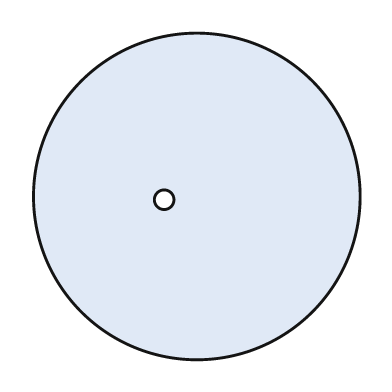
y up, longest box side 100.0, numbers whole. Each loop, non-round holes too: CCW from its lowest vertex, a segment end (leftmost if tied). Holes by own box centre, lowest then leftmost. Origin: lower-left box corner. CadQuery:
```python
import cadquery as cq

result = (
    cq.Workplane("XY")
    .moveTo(50.0, 50.0)
    .circle(50.0)
    .moveTo(40.0, 49.0)
    .circle(3.0)
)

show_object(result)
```